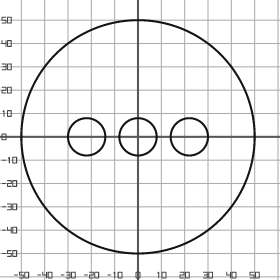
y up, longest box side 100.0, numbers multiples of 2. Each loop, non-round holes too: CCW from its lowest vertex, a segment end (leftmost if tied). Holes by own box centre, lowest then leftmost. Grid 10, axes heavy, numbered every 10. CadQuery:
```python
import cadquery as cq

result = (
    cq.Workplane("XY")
    .moveTo(0.0, 0.0)
    .circle(50.0)
    .moveTo(-22.0, 0.0)
    .circle(8.0)
    .moveTo(0.0, 0.0)
    .circle(8.0)
    .moveTo(22.0, 0.0)
    .circle(8.0)
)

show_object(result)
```